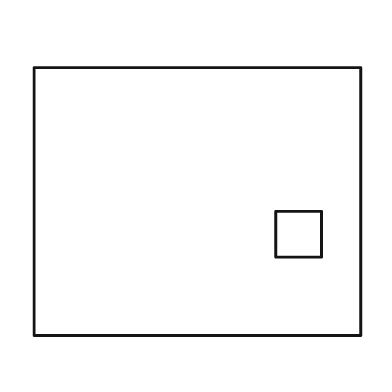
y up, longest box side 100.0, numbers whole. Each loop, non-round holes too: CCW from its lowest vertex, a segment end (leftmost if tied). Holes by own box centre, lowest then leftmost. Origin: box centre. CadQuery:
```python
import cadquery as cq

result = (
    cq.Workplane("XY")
    .moveTo(-50.0, -41.0)
    .lineTo(50.0, -41.0)
    .lineTo(50.0, 41.0)
    .lineTo(-50.0, 41.0)
    .close()
    .moveTo(24.0, -17.0)
    .lineTo(38.0, -17.0)
    .lineTo(38.0, -3.0)
    .lineTo(24.0, -3.0)
    .close()
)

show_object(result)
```